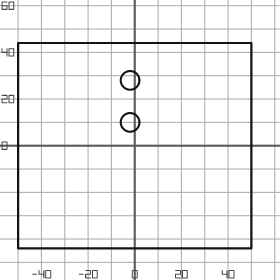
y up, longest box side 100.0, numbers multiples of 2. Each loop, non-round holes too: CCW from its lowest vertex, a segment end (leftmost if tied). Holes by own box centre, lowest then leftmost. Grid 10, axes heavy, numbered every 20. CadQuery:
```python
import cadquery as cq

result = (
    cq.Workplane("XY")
    .moveTo(-50.0, -44.0)
    .lineTo(50.0, -44.0)
    .lineTo(50.0, 44.0)
    .lineTo(-50.0, 44.0)
    .close()
    .moveTo(-2.0, 10.0)
    .circle(4.0)
    .moveTo(-2.0, 28.0)
    .circle(4.0)
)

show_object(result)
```